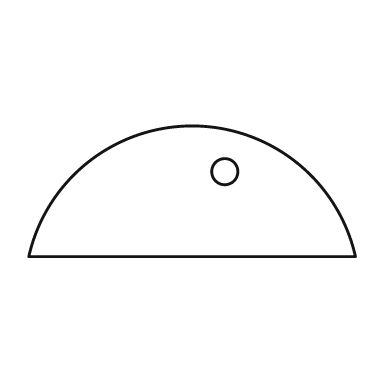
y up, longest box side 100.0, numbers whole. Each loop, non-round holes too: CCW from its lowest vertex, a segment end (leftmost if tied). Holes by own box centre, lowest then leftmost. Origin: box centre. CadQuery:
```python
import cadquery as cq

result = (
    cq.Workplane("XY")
    .moveTo(-50.0, -20.0)
    .lineTo(50.0, -20.0)
    .threePointArc((0.0, 20.0), (-50.0, -20.0))
    .close()
    .moveTo(10.0, 6.0)
    .circle(4.0)
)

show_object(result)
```